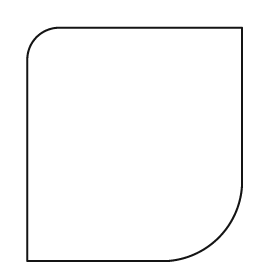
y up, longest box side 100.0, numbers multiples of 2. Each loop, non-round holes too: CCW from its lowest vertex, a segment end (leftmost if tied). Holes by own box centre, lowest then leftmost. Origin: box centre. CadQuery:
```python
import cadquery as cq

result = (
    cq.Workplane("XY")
    .moveTo(-46.0, -50.0)
    .lineTo(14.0, -50.0)
    .threePointArc((36.0, -40.0), (46.0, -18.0))
    .lineTo(46.0, 50.0)
    .lineTo(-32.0, 50.0)
    .threePointArc((-42.0, 46.0), (-46.0, 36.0))
    .close()
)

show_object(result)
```